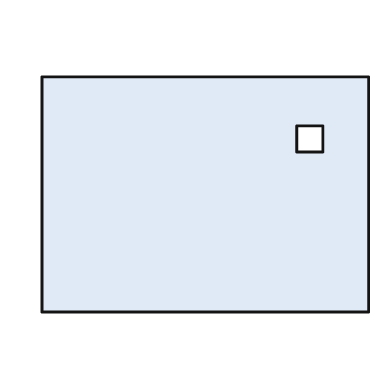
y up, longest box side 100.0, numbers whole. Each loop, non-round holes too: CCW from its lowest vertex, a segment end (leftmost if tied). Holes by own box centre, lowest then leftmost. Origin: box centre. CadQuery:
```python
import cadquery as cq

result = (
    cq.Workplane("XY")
    .moveTo(-50.0, -36.0)
    .lineTo(50.0, -36.0)
    .lineTo(50.0, 36.0)
    .lineTo(-50.0, 36.0)
    .close()
    .moveTo(28.0, 13.0)
    .lineTo(36.0, 13.0)
    .lineTo(36.0, 21.0)
    .lineTo(28.0, 21.0)
    .close()
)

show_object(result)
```